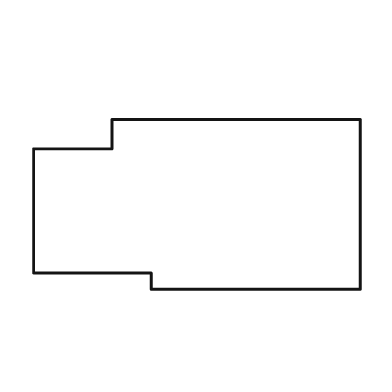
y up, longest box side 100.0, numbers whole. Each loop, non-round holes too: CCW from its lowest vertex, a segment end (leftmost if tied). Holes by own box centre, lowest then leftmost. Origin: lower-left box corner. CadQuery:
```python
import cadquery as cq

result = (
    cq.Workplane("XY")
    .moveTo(36.0, 0.0)
    .lineTo(100.0, 0.0)
    .lineTo(100.0, 52.0)
    .lineTo(24.0, 52.0)
    .lineTo(24.0, 43.0)
    .lineTo(0.0, 43.0)
    .lineTo(0.0, 5.0)
    .lineTo(36.0, 5.0)
    .close()
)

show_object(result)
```